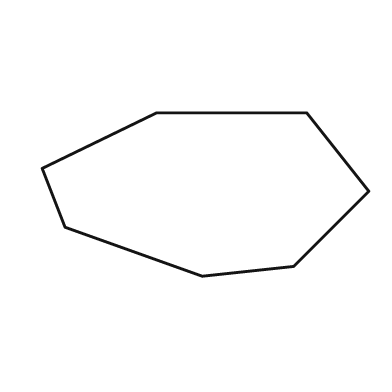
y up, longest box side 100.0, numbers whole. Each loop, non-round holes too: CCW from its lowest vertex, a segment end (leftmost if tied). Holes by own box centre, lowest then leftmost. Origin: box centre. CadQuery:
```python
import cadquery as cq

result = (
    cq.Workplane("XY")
    .moveTo(-1.0, -25.0)
    .lineTo(27.0, -22.0)
    .lineTo(50.0, 1.0)
    .lineTo(31.0, 25.0)
    .lineTo(-15.0, 25.0)
    .lineTo(-50.0, 8.0)
    .lineTo(-43.0, -10.0)
    .close()
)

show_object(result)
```